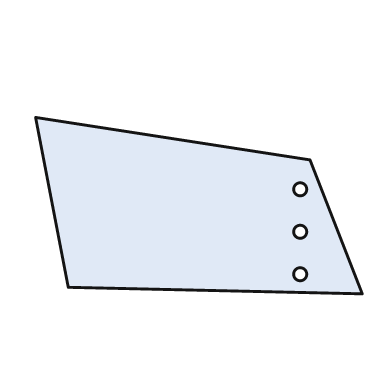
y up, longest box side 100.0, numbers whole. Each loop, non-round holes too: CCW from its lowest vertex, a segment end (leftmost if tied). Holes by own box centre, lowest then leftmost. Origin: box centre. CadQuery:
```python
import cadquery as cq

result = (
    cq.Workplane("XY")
    .moveTo(50.0, -27.0)
    .lineTo(34.0, 14.0)
    .lineTo(-50.0, 27.0)
    .lineTo(-40.0, -25.0)
    .close()
    .moveTo(31.0, -21.0)
    .circle(2.0)
    .moveTo(31.0, -8.0)
    .circle(2.0)
    .moveTo(31.0, 5.0)
    .circle(2.0)
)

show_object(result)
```